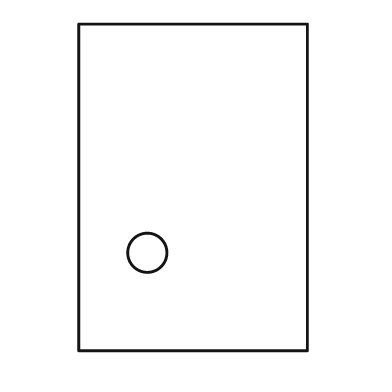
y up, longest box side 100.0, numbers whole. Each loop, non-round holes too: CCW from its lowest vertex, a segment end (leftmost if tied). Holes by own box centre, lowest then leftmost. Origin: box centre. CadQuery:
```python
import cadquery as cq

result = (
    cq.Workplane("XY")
    .moveTo(-35.0, -50.0)
    .lineTo(35.0, -50.0)
    .lineTo(35.0, 50.0)
    .lineTo(-35.0, 50.0)
    .close()
    .moveTo(-14.0, -20.0)
    .circle(6.0)
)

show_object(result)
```